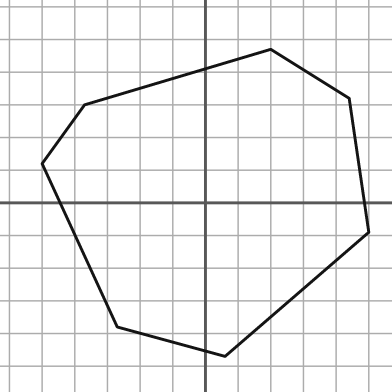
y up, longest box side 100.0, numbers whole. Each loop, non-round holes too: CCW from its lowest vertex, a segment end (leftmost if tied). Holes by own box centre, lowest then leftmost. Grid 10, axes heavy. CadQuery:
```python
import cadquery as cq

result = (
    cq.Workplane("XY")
    .moveTo(6.0, -47.0)
    .lineTo(50.0, -9.0)
    .lineTo(44.0, 32.0)
    .lineTo(20.0, 47.0)
    .lineTo(-37.0, 30.0)
    .lineTo(-50.0, 12.0)
    .lineTo(-27.0, -38.0)
    .close()
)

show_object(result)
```